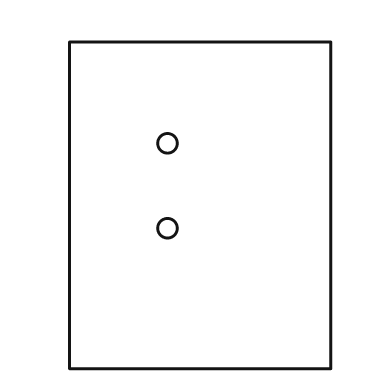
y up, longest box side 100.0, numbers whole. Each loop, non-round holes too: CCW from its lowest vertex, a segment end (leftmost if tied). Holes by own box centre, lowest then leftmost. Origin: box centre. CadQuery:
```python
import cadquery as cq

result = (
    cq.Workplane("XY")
    .moveTo(-40.0, -50.0)
    .lineTo(40.0, -50.0)
    .lineTo(40.0, 50.0)
    .lineTo(-40.0, 50.0)
    .close()
    .moveTo(-10.0, -7.0)
    .circle(3.0)
    .moveTo(-10.0, 19.0)
    .circle(3.0)
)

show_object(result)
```